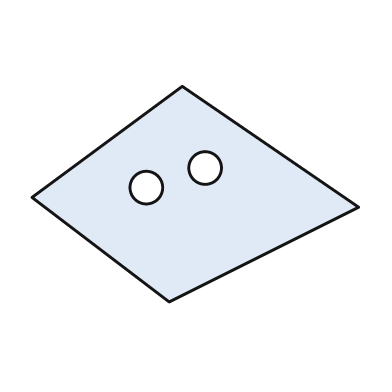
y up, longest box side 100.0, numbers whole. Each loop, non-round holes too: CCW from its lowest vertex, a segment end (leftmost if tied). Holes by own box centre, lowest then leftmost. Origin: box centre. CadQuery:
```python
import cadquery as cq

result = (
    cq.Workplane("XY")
    .moveTo(-8.0, -33.0)
    .lineTo(50.0, -4.0)
    .lineTo(-4.0, 33.0)
    .lineTo(-50.0, -1.0)
    .close()
    .moveTo(-15.0, 2.0)
    .circle(5.0)
    .moveTo(3.0, 8.0)
    .circle(5.0)
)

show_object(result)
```